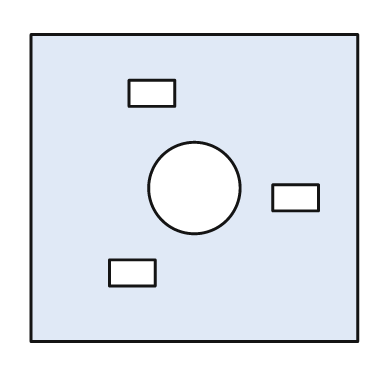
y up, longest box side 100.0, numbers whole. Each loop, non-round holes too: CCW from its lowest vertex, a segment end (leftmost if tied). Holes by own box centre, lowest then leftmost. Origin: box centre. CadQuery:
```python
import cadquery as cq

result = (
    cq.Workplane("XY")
    .moveTo(-50.0, -47.0)
    .lineTo(50.0, -47.0)
    .lineTo(50.0, 47.0)
    .lineTo(-50.0, 47.0)
    .close()
    .moveTo(-26.0, -30.0)
    .lineTo(-12.0, -30.0)
    .lineTo(-12.0, -22.0)
    .lineTo(-26.0, -22.0)
    .close()
    .moveTo(24.0, -7.0)
    .lineTo(38.0, -7.0)
    .lineTo(38.0, 1.0)
    .lineTo(24.0, 1.0)
    .close()
    .moveTo(0.0, 0.0)
    .circle(14.0)
    .moveTo(-20.0, 25.0)
    .lineTo(-6.0, 25.0)
    .lineTo(-6.0, 33.0)
    .lineTo(-20.0, 33.0)
    .close()
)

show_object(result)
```